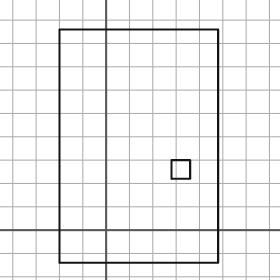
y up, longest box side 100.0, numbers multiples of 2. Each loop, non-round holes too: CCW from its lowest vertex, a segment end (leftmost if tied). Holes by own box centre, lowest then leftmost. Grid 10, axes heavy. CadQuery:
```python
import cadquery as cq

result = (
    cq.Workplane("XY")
    .moveTo(-20.0, -14.0)
    .lineTo(48.0, -14.0)
    .lineTo(48.0, 86.0)
    .lineTo(-20.0, 86.0)
    .close()
    .moveTo(28.0, 22.0)
    .lineTo(36.0, 22.0)
    .lineTo(36.0, 30.0)
    .lineTo(28.0, 30.0)
    .close()
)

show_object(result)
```